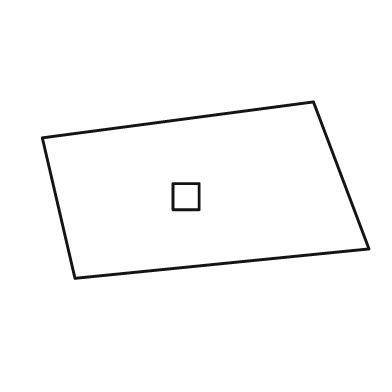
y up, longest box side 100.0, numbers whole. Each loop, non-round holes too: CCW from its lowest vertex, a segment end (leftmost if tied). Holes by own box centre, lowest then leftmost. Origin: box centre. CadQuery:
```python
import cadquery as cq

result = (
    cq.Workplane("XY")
    .moveTo(-40.0, -27.0)
    .lineTo(50.0, -18.0)
    .lineTo(33.0, 27.0)
    .lineTo(-50.0, 16.0)
    .close()
    .moveTo(-10.0, -6.0)
    .lineTo(-2.0, -6.0)
    .lineTo(-2.0, 2.0)
    .lineTo(-10.0, 2.0)
    .close()
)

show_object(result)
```